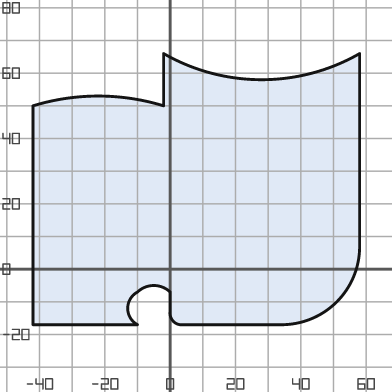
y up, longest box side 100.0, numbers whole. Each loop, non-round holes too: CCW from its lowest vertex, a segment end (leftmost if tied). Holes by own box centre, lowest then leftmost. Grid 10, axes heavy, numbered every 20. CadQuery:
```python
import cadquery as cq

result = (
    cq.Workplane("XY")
    .moveTo(-42.0, -17.0)
    .lineTo(-10.0, -17.0)
    .threePointArc((-13.0, -12.0), (-10.0, -7.0))
    .threePointArc((-5.0, -5.0), (0.0, -7.0))
    .lineTo(0.0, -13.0)
    .threePointArc((1.0, -16.0), (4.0, -17.0))
    .lineTo(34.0, -17.0)
    .threePointArc((51.0, -10.0), (58.0, 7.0))
    .lineTo(58.0, 66.0)
    .threePointArc((28.0, 58.0), (-2.0, 66.0))
    .lineTo(-2.0, 50.0)
    .threePointArc((-22.0, 53.0), (-42.0, 50.0))
    .close()
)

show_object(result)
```